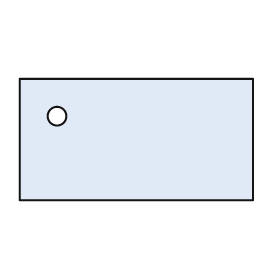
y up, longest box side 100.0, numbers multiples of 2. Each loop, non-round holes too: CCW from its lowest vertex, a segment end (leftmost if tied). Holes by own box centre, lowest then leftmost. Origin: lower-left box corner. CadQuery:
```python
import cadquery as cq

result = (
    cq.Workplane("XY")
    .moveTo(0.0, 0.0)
    .lineTo(100.0, 0.0)
    .lineTo(100.0, 52.0)
    .lineTo(0.0, 52.0)
    .close()
    .moveTo(16.0, 36.0)
    .circle(4.0)
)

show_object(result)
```